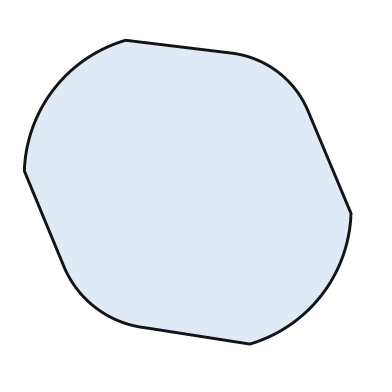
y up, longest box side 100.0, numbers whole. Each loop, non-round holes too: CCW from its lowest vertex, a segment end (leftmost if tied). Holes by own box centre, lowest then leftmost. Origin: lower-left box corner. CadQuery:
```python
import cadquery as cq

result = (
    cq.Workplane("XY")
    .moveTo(69.0, 0.0)
    .threePointArc((91.0, 15.0), (100.0, 40.0))
    .lineTo(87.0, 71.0)
    .threePointArc((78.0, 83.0), (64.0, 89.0))
    .lineTo(31.0, 93.0)
    .threePointArc((9.0, 78.0), (0.0, 53.0))
    .lineTo(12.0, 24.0)
    .threePointArc((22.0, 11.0), (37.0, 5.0))
    .close()
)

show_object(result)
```